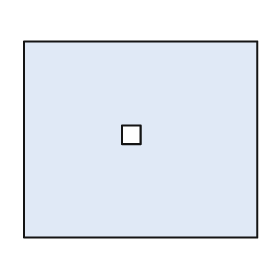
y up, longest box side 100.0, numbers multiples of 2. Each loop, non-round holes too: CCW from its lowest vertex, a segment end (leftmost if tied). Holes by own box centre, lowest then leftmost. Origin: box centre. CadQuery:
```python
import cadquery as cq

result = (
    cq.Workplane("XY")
    .moveTo(-50.0, -42.0)
    .lineTo(50.0, -42.0)
    .lineTo(50.0, 42.0)
    .lineTo(-50.0, 42.0)
    .close()
    .moveTo(-8.0, -2.0)
    .lineTo(0.0, -2.0)
    .lineTo(0.0, 6.0)
    .lineTo(-8.0, 6.0)
    .close()
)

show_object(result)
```